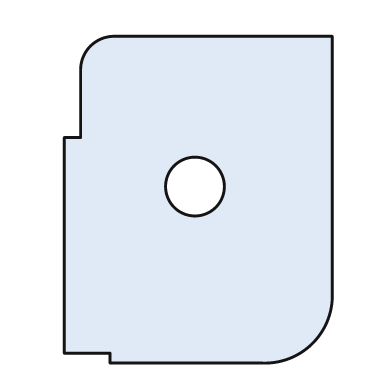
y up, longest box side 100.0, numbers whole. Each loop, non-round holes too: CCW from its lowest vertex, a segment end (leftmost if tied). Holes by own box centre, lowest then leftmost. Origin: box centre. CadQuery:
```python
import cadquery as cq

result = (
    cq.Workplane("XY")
    .moveTo(-27.0, -50.0)
    .lineTo(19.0, -50.0)
    .threePointArc((35.0, -44.0), (41.0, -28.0))
    .lineTo(41.0, 50.0)
    .lineTo(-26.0, 50.0)
    .threePointArc((-33.0, 47.0), (-36.0, 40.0))
    .lineTo(-36.0, 19.0)
    .lineTo(-41.0, 19.0)
    .lineTo(-41.0, -47.0)
    .lineTo(-27.0, -47.0)
    .close()
    .moveTo(-1.0, 4.0)
    .circle(9.0)
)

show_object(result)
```